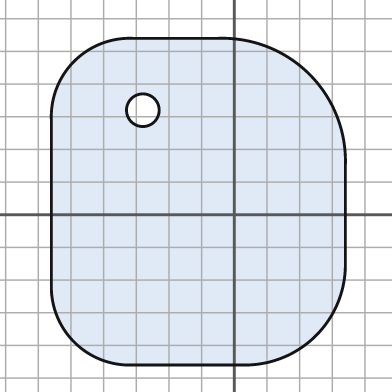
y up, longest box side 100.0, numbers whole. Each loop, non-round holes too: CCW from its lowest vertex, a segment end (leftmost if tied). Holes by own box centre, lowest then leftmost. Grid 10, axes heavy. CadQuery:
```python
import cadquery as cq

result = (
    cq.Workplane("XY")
    .moveTo(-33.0, -46.0)
    .lineTo(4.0, -46.0)
    .threePointArc((25.0, -37.0), (34.0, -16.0))
    .lineTo(34.0, 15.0)
    .threePointArc((23.0, 43.0), (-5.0, 54.0))
    .lineTo(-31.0, 54.0)
    .threePointArc((-49.0, 47.0), (-56.0, 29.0))
    .lineTo(-56.0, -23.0)
    .threePointArc((-49.0, -39.0), (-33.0, -46.0))
    .close()
    .moveTo(-28.0, 32.0)
    .circle(5.0)
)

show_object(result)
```